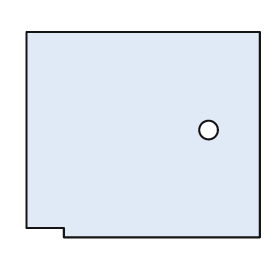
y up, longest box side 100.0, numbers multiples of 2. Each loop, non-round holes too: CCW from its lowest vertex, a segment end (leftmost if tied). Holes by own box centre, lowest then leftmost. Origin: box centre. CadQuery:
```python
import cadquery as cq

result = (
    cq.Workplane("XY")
    .moveTo(-34.0, -44.0)
    .lineTo(50.0, -44.0)
    .lineTo(50.0, 44.0)
    .lineTo(-50.0, 44.0)
    .lineTo(-50.0, -40.0)
    .lineTo(-34.0, -40.0)
    .close()
    .moveTo(28.0, 2.0)
    .circle(4.0)
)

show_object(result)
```